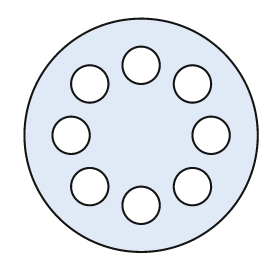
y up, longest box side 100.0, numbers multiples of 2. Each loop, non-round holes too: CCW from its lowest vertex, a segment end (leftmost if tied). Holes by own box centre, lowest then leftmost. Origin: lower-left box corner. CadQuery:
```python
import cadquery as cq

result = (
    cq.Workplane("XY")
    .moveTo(50.0, 50.0)
    .circle(50.0)
    .moveTo(50.0, 20.0)
    .circle(8.0)
    .moveTo(28.0, 28.0)
    .circle(8.0)
    .moveTo(72.0, 28.0)
    .circle(8.0)
    .moveTo(20.0, 50.0)
    .circle(8.0)
    .moveTo(80.0, 50.0)
    .circle(8.0)
    .moveTo(28.0, 72.0)
    .circle(8.0)
    .moveTo(72.0, 72.0)
    .circle(8.0)
    .moveTo(50.0, 80.0)
    .circle(8.0)
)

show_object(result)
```